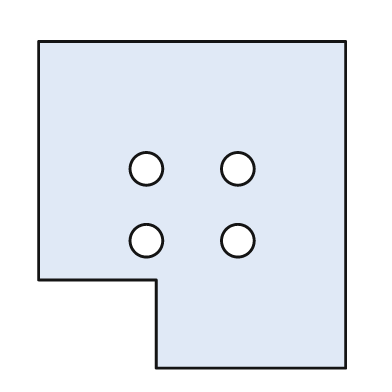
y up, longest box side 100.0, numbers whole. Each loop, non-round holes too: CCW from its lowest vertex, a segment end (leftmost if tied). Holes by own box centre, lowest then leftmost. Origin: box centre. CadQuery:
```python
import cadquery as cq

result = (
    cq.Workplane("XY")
    .moveTo(-11.0, -50.0)
    .lineTo(47.0, -50.0)
    .lineTo(47.0, 50.0)
    .lineTo(-47.0, 50.0)
    .lineTo(-47.0, -23.0)
    .lineTo(-11.0, -23.0)
    .close()
    .moveTo(-14.0, -11.0)
    .circle(5.0)
    .moveTo(14.0, -11.0)
    .circle(5.0)
    .moveTo(-14.0, 11.0)
    .circle(5.0)
    .moveTo(14.0, 11.0)
    .circle(5.0)
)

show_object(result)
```